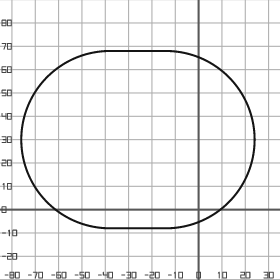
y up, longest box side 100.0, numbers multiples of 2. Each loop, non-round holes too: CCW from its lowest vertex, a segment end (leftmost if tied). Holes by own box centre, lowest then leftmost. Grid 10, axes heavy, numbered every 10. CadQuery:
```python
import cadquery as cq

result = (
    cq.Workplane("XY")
    .moveTo(-38.0, -8.0)
    .lineTo(-14.0, -8.0)
    .threePointArc((24.0, 30.0), (-14.0, 68.0))
    .lineTo(-38.0, 68.0)
    .threePointArc((-76.0, 30.0), (-38.0, -8.0))
    .close()
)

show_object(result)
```